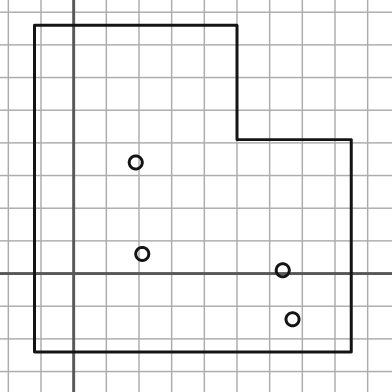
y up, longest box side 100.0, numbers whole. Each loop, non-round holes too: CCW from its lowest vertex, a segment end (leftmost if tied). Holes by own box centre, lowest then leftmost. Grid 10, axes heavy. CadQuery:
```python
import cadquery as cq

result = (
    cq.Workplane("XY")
    .moveTo(-12.0, -24.0)
    .lineTo(85.0, -24.0)
    .lineTo(85.0, 41.0)
    .lineTo(50.0, 41.0)
    .lineTo(50.0, 76.0)
    .lineTo(-12.0, 76.0)
    .close()
    .moveTo(67.0, -14.0)
    .circle(2.0)
    .moveTo(64.0, 1.0)
    .circle(2.0)
    .moveTo(21.0, 6.0)
    .circle(2.0)
    .moveTo(19.0, 34.0)
    .circle(2.0)
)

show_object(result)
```